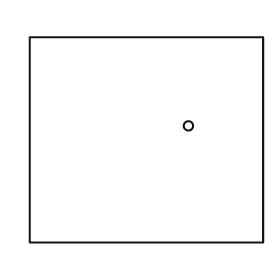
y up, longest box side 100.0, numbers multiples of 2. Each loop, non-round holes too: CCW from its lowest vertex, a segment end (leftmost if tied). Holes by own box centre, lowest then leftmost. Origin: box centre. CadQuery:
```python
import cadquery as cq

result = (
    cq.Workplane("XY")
    .moveTo(-50.0, -44.0)
    .lineTo(50.0, -44.0)
    .lineTo(50.0, 44.0)
    .lineTo(-50.0, 44.0)
    .close()
    .moveTo(18.0, 6.0)
    .circle(2.0)
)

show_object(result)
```